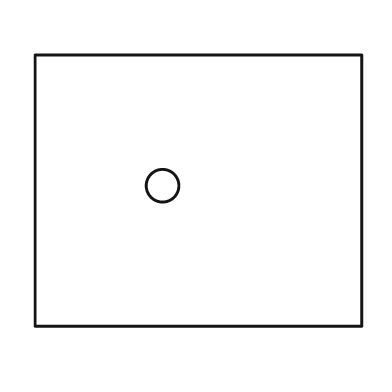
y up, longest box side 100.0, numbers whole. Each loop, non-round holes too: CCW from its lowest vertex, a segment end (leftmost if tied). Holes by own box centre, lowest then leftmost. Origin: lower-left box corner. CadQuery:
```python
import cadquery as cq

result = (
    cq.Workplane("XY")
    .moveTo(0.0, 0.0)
    .lineTo(100.0, 0.0)
    .lineTo(100.0, 83.0)
    .lineTo(0.0, 83.0)
    .close()
    .moveTo(39.0, 43.0)
    .circle(5.0)
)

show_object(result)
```